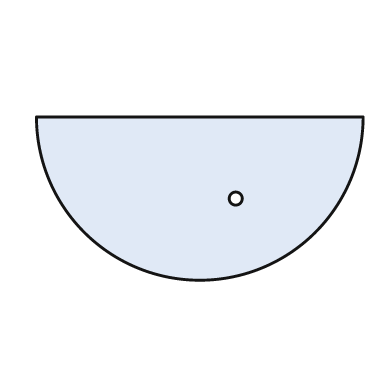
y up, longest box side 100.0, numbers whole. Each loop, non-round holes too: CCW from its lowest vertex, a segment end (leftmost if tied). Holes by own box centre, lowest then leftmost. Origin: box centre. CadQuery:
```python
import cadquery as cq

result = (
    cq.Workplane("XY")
    .moveTo(-50.0, 25.0)
    .threePointArc((0.0, -25.0), (50.0, 25.0))
    .close()
    .moveTo(11.0, 0.0)
    .circle(2.0)
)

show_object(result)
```